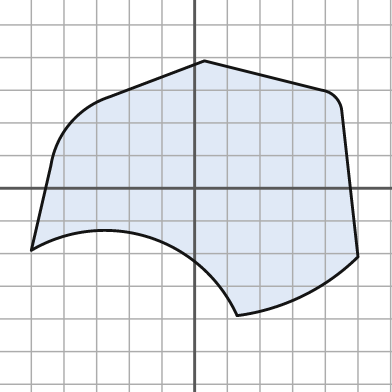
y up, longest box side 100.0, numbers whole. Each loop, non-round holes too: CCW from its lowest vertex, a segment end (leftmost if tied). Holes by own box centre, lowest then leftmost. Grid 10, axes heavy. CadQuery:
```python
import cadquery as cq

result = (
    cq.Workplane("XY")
    .moveTo(13.0, -39.0)
    .threePointArc((33.0, -33.0), (50.0, -21.0))
    .lineTo(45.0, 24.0)
    .threePointArc((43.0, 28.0), (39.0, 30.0))
    .lineTo(3.0, 39.0)
    .lineTo(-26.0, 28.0)
    .threePointArc((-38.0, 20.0), (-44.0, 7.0))
    .lineTo(-50.0, -19.0)
    .threePointArc((-14.0, -15.0), (13.0, -39.0))
    .close()
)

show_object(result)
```